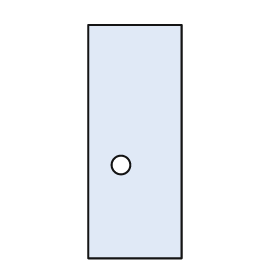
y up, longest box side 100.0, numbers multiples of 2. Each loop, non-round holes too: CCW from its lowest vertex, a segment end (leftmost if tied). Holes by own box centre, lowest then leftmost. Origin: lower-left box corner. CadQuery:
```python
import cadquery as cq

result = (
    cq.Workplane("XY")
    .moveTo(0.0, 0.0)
    .lineTo(40.0, 0.0)
    .lineTo(40.0, 100.0)
    .lineTo(0.0, 100.0)
    .close()
    .moveTo(14.0, 40.0)
    .circle(4.0)
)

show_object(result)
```